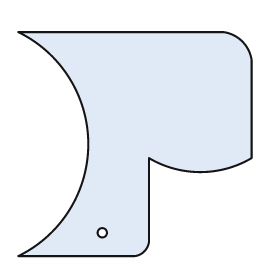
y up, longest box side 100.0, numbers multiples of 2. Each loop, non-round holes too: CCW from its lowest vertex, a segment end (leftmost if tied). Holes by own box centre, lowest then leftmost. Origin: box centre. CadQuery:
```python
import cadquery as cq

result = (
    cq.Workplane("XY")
    .moveTo(-50.0, -48.0)
    .lineTo(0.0, -48.0)
    .threePointArc((4.0, -46.0), (6.0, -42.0))
    .lineTo(6.0, -6.0)
    .threePointArc((28.0, -12.0), (50.0, -6.0))
    .lineTo(50.0, 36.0)
    .threePointArc((46.0, 44.0), (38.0, 48.0))
    .lineTo(-50.0, 48.0)
    .threePointArc((-20.0, 0.0), (-50.0, -48.0))
    .close()
    .moveTo(-14.0, -38.0)
    .circle(2.0)
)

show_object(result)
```